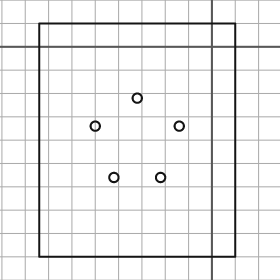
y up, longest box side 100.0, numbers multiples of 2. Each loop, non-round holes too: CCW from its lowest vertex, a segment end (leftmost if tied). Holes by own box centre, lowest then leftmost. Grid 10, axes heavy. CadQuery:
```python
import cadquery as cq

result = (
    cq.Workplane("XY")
    .moveTo(-74.0, -90.0)
    .lineTo(10.0, -90.0)
    .lineTo(10.0, 10.0)
    .lineTo(-74.0, 10.0)
    .close()
    .moveTo(-42.0, -56.0)
    .circle(2.0)
    .moveTo(-22.0, -56.0)
    .circle(2.0)
    .moveTo(-50.0, -34.0)
    .circle(2.0)
    .moveTo(-14.0, -34.0)
    .circle(2.0)
    .moveTo(-32.0, -22.0)
    .circle(2.0)
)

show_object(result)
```